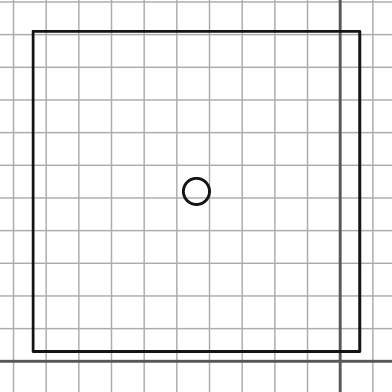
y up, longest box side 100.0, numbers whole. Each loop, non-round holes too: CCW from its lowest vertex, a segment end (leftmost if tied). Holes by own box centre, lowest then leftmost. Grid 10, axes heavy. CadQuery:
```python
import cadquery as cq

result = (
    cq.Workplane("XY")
    .moveTo(-94.0, 3.0)
    .lineTo(6.0, 3.0)
    .lineTo(6.0, 101.0)
    .lineTo(-94.0, 101.0)
    .close()
    .moveTo(-44.0, 52.0)
    .circle(4.0)
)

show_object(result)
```